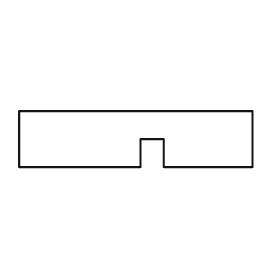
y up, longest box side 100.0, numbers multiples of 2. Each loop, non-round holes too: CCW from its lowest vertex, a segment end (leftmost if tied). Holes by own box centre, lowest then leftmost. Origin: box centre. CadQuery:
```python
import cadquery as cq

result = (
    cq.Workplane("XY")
    .moveTo(-50.0, -12.0)
    .lineTo(2.0, -12.0)
    .lineTo(2.0, 0.0)
    .lineTo(12.0, 0.0)
    .lineTo(12.0, -12.0)
    .lineTo(50.0, -12.0)
    .lineTo(50.0, 12.0)
    .lineTo(-50.0, 12.0)
    .close()
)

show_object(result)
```